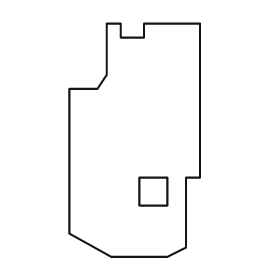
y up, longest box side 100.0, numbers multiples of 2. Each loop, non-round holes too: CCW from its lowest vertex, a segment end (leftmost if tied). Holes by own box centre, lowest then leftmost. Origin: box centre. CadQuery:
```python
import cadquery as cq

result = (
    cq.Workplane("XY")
    .moveTo(-10.0, -50.0)
    .lineTo(14.0, -50.0)
    .lineTo(22.0, -46.0)
    .lineTo(22.0, -16.0)
    .lineTo(28.0, -16.0)
    .lineTo(28.0, 50.0)
    .lineTo(4.0, 50.0)
    .lineTo(4.0, 44.0)
    .lineTo(-6.0, 44.0)
    .lineTo(-6.0, 50.0)
    .lineTo(-12.0, 50.0)
    .lineTo(-12.0, 28.0)
    .lineTo(-16.0, 22.0)
    .lineTo(-28.0, 22.0)
    .lineTo(-28.0, -40.0)
    .close()
    .moveTo(2.0, -28.0)
    .lineTo(14.0, -28.0)
    .lineTo(14.0, -16.0)
    .lineTo(2.0, -16.0)
    .close()
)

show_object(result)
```